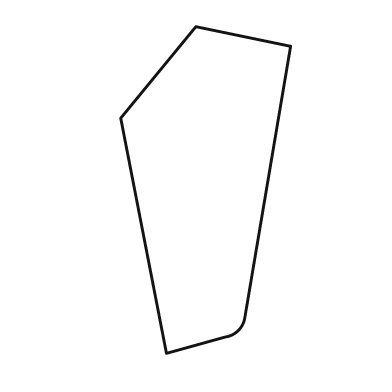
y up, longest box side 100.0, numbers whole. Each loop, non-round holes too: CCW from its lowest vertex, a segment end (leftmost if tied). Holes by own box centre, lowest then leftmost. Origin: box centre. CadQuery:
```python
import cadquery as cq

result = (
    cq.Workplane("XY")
    .moveTo(-12.0, -50.0)
    .lineTo(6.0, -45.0)
    .threePointArc((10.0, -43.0), (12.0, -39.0))
    .lineTo(26.0, 44.0)
    .lineTo(-3.0, 50.0)
    .lineTo(-26.0, 22.0)
    .close()
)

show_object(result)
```